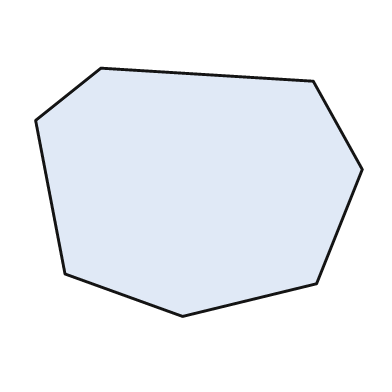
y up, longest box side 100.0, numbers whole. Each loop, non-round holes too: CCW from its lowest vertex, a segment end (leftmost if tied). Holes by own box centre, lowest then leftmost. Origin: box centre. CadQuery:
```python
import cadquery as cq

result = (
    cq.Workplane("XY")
    .moveTo(-5.0, -38.0)
    .lineTo(36.0, -28.0)
    .lineTo(50.0, 7.0)
    .lineTo(35.0, 34.0)
    .lineTo(-30.0, 38.0)
    .lineTo(-50.0, 22.0)
    .lineTo(-41.0, -25.0)
    .close()
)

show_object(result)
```